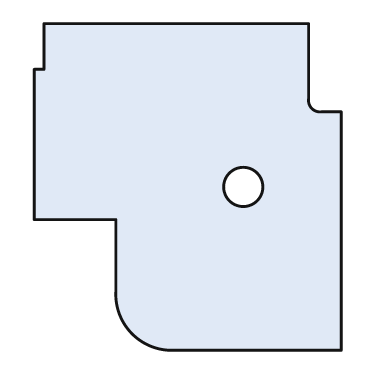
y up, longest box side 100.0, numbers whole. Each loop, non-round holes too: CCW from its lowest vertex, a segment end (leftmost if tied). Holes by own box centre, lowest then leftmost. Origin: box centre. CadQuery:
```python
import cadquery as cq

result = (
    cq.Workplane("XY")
    .moveTo(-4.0, -50.0)
    .lineTo(47.0, -50.0)
    .lineTo(47.0, 23.0)
    .lineTo(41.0, 23.0)
    .threePointArc((38.0, 24.0), (37.0, 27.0))
    .lineTo(37.0, 50.0)
    .lineTo(-44.0, 50.0)
    .lineTo(-44.0, 36.0)
    .lineTo(-47.0, 36.0)
    .lineTo(-47.0, -10.0)
    .lineTo(-22.0, -10.0)
    .lineTo(-22.0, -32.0)
    .threePointArc((-17.0, -45.0), (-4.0, -50.0))
    .close()
    .moveTo(17.0, 0.0)
    .circle(6.0)
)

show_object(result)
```